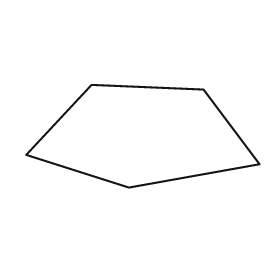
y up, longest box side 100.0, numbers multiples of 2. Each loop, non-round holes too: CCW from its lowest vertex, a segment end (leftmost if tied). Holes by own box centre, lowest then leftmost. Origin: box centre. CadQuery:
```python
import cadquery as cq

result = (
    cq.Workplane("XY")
    .moveTo(-6.0, -22.0)
    .lineTo(50.0, -12.0)
    .lineTo(26.0, 20.0)
    .lineTo(-22.0, 22.0)
    .lineTo(-50.0, -8.0)
    .close()
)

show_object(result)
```